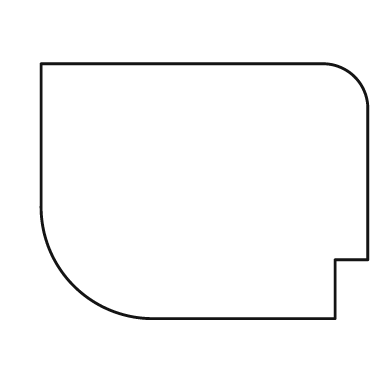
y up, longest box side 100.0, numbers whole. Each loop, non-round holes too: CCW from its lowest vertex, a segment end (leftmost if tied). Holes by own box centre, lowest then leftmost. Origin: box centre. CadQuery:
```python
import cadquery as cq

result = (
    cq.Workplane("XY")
    .moveTo(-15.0, -39.0)
    .lineTo(40.0, -39.0)
    .lineTo(40.0, -21.0)
    .lineTo(50.0, -21.0)
    .lineTo(50.0, 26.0)
    .threePointArc((46.0, 35.0), (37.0, 39.0))
    .lineTo(-50.0, 39.0)
    .lineTo(-50.0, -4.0)
    .threePointArc((-40.0, -29.0), (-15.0, -39.0))
    .close()
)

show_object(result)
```